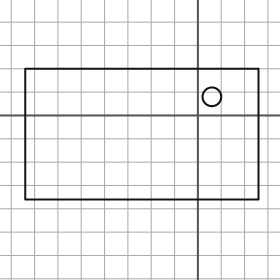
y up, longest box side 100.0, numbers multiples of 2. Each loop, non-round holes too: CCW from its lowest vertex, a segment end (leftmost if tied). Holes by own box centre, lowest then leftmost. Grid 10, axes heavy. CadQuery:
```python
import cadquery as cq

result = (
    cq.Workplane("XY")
    .moveTo(-74.0, -36.0)
    .lineTo(26.0, -36.0)
    .lineTo(26.0, 20.0)
    .lineTo(-74.0, 20.0)
    .close()
    .moveTo(6.0, 8.0)
    .circle(4.0)
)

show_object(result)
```